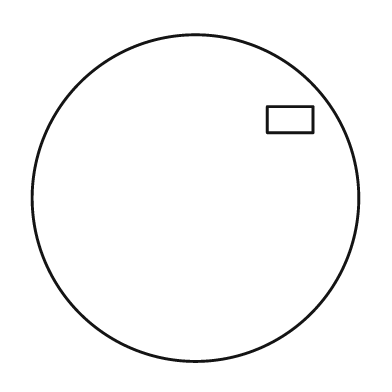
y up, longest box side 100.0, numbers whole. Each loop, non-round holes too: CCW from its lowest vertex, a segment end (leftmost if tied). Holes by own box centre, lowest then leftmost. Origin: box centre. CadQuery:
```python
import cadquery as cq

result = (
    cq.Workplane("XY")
    .moveTo(0.0, 0.0)
    .circle(50.0)
    .moveTo(22.0, 20.0)
    .lineTo(36.0, 20.0)
    .lineTo(36.0, 28.0)
    .lineTo(22.0, 28.0)
    .close()
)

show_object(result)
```